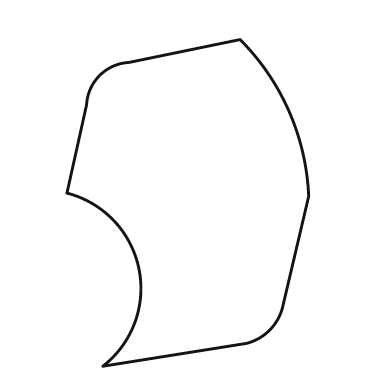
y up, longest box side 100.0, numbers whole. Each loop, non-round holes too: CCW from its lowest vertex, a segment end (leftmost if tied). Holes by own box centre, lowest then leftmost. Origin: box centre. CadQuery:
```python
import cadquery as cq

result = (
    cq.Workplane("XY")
    .moveTo(-26.0, -50.0)
    .lineTo(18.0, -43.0)
    .threePointArc((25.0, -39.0), (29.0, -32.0))
    .lineTo(37.0, 2.0)
    .threePointArc((31.0, 28.0), (16.0, 50.0))
    .lineTo(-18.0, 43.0)
    .threePointArc((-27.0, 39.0), (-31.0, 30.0))
    .lineTo(-37.0, 3.0)
    .threePointArc((-15.0, -20.0), (-26.0, -50.0))
    .close()
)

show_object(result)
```